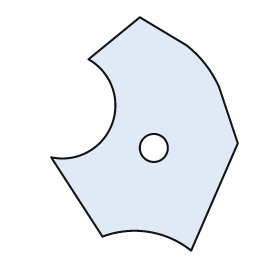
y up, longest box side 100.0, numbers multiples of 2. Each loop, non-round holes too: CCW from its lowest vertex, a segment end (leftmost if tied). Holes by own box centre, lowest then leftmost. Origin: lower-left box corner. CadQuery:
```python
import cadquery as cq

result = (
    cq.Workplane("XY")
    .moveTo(60.0, 0.0)
    .lineTo(80.0, 46.0)
    .lineTo(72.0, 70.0)
    .threePointArc((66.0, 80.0), (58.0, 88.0))
    .lineTo(38.0, 100.0)
    .lineTo(16.0, 82.0)
    .threePointArc((26.0, 54.0), (0.0, 40.0))
    .lineTo(22.0, 6.0)
    .threePointArc((42.0, 8.0), (60.0, 0.0))
    .close()
    .moveTo(44.0, 44.0)
    .circle(6.0)
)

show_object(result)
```